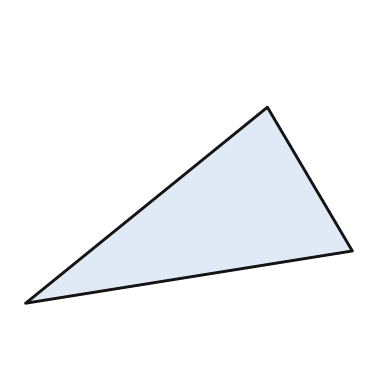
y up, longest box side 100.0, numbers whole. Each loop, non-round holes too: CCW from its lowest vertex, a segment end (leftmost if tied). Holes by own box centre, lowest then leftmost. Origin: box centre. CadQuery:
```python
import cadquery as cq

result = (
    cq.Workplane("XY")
    .moveTo(-50.0, -30.0)
    .lineTo(50.0, -14.0)
    .lineTo(24.0, 30.0)
    .close()
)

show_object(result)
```